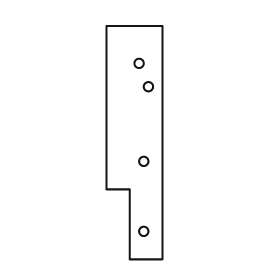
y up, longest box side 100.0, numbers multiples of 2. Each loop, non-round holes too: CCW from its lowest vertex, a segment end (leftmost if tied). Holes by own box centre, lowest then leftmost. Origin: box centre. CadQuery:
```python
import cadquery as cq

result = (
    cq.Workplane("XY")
    .moveTo(-2.0, -50.0)
    .lineTo(12.0, -50.0)
    .lineTo(12.0, 50.0)
    .lineTo(-12.0, 50.0)
    .lineTo(-12.0, -20.0)
    .lineTo(-2.0, -20.0)
    .close()
    .moveTo(4.0, -38.0)
    .circle(2.0)
    .moveTo(4.0, -8.0)
    .circle(2.0)
    .moveTo(6.0, 24.0)
    .circle(2.0)
    .moveTo(2.0, 34.0)
    .circle(2.0)
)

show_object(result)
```